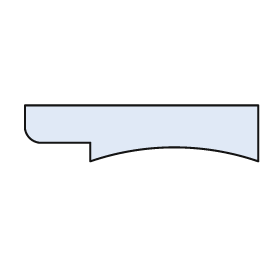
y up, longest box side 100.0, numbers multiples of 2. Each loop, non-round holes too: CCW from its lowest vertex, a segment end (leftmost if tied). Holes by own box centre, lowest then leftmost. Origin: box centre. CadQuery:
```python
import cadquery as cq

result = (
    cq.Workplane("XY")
    .moveTo(-22.0, -12.0)
    .threePointArc((14.0, -6.0), (50.0, -12.0))
    .lineTo(50.0, 12.0)
    .lineTo(-50.0, 12.0)
    .lineTo(-50.0, 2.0)
    .threePointArc((-48.0, -2.0), (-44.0, -4.0))
    .lineTo(-22.0, -4.0)
    .close()
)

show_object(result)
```